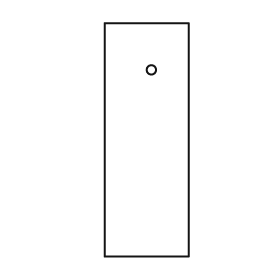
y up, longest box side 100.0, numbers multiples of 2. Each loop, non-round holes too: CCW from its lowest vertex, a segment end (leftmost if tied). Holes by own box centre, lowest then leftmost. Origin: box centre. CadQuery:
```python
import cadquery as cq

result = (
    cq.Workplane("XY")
    .moveTo(-18.0, -50.0)
    .lineTo(18.0, -50.0)
    .lineTo(18.0, 50.0)
    .lineTo(-18.0, 50.0)
    .close()
    .moveTo(2.0, 30.0)
    .circle(2.0)
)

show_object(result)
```